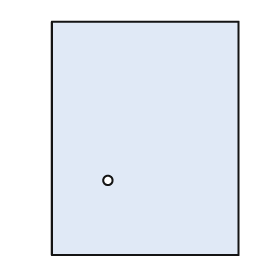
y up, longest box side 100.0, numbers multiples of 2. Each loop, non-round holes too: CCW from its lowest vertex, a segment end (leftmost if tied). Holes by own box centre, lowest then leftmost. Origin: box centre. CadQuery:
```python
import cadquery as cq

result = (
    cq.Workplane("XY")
    .moveTo(-40.0, -50.0)
    .lineTo(40.0, -50.0)
    .lineTo(40.0, 50.0)
    .lineTo(-40.0, 50.0)
    .close()
    .moveTo(-16.0, -18.0)
    .circle(2.0)
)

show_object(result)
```